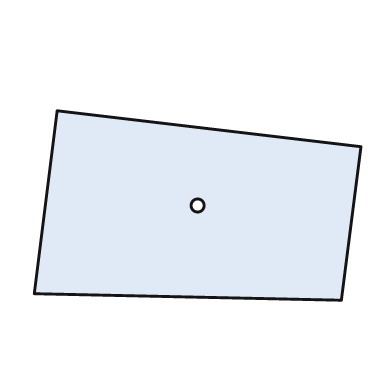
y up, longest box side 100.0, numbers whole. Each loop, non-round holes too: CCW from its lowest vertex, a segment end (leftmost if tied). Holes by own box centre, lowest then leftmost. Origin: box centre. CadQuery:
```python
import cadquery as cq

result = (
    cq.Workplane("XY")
    .moveTo(44.0, -29.0)
    .lineTo(50.0, 18.0)
    .lineTo(-43.0, 29.0)
    .lineTo(-50.0, -27.0)
    .close()
    .moveTo(0.0, 0.0)
    .circle(2.0)
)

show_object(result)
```